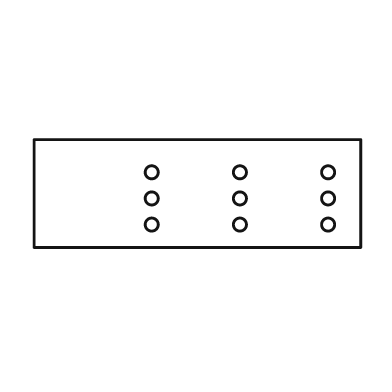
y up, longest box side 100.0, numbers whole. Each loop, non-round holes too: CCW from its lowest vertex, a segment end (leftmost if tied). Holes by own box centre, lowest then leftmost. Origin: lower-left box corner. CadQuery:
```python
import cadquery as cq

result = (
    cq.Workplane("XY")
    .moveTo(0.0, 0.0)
    .lineTo(100.0, 0.0)
    .lineTo(100.0, 33.0)
    .lineTo(0.0, 33.0)
    .close()
    .moveTo(36.0, 7.0)
    .circle(2.0)
    .moveTo(63.0, 7.0)
    .circle(2.0)
    .moveTo(90.0, 7.0)
    .circle(2.0)
    .moveTo(36.0, 15.0)
    .circle(2.0)
    .moveTo(63.0, 15.0)
    .circle(2.0)
    .moveTo(90.0, 15.0)
    .circle(2.0)
    .moveTo(36.0, 23.0)
    .circle(2.0)
    .moveTo(63.0, 23.0)
    .circle(2.0)
    .moveTo(90.0, 23.0)
    .circle(2.0)
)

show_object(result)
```